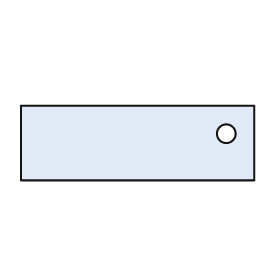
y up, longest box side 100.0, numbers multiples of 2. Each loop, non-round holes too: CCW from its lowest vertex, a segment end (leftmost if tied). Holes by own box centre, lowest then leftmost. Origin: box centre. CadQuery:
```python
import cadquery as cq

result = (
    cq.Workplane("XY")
    .moveTo(-50.0, -16.0)
    .lineTo(50.0, -16.0)
    .lineTo(50.0, 16.0)
    .lineTo(-50.0, 16.0)
    .close()
    .moveTo(38.0, 4.0)
    .circle(4.0)
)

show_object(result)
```